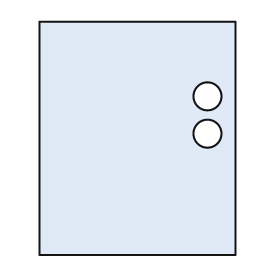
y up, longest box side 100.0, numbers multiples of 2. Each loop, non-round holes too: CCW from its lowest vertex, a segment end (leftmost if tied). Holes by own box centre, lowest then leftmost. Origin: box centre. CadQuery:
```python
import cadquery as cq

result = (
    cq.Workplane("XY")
    .moveTo(-42.0, -50.0)
    .lineTo(42.0, -50.0)
    .lineTo(42.0, 50.0)
    .lineTo(-42.0, 50.0)
    .close()
    .moveTo(30.0, 2.0)
    .circle(6.0)
    .moveTo(30.0, 18.0)
    .circle(6.0)
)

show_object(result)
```